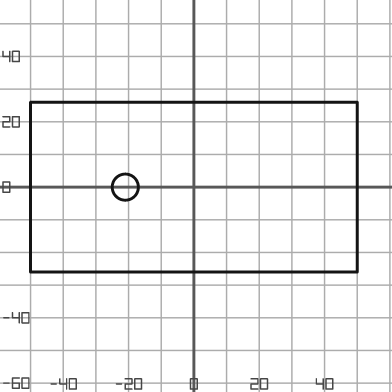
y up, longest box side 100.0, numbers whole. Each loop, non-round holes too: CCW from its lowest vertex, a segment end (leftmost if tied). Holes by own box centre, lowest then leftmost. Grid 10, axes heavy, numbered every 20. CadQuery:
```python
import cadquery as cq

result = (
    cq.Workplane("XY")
    .moveTo(-50.0, -26.0)
    .lineTo(50.0, -26.0)
    .lineTo(50.0, 26.0)
    .lineTo(-50.0, 26.0)
    .close()
    .moveTo(-21.0, 0.0)
    .circle(4.0)
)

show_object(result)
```